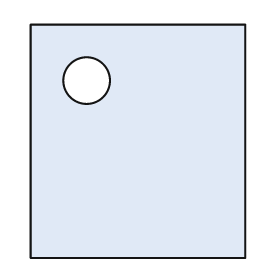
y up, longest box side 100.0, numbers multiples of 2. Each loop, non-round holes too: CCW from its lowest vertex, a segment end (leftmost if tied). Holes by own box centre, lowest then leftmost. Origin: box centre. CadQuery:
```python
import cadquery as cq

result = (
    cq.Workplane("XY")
    .moveTo(-46.0, -50.0)
    .lineTo(46.0, -50.0)
    .lineTo(46.0, 50.0)
    .lineTo(-46.0, 50.0)
    .close()
    .moveTo(-22.0, 26.0)
    .circle(10.0)
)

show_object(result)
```